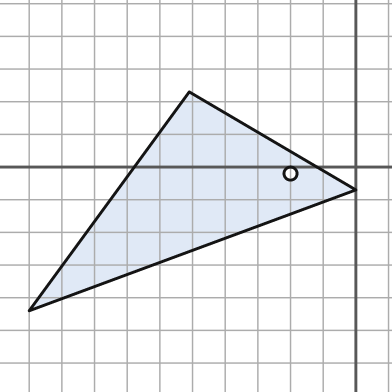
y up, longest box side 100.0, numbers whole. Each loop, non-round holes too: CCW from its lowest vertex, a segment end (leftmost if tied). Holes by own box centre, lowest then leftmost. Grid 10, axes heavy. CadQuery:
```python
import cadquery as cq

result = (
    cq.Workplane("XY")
    .moveTo(-100.0, -44.0)
    .lineTo(0.0, -7.0)
    .lineTo(-51.0, 23.0)
    .close()
    .moveTo(-20.0, -2.0)
    .circle(2.0)
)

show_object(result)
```